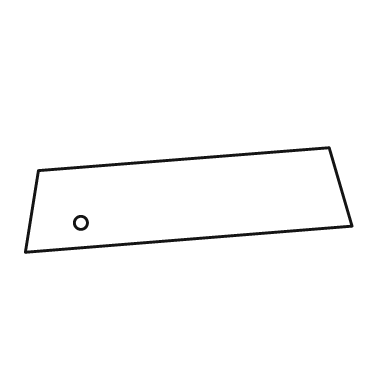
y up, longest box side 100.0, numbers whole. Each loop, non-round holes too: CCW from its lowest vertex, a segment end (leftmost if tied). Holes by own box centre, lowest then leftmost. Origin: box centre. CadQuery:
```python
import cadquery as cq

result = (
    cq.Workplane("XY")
    .moveTo(-50.0, -16.0)
    .lineTo(50.0, -8.0)
    .lineTo(43.0, 16.0)
    .lineTo(-46.0, 9.0)
    .close()
    .moveTo(-33.0, -7.0)
    .circle(2.0)
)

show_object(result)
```